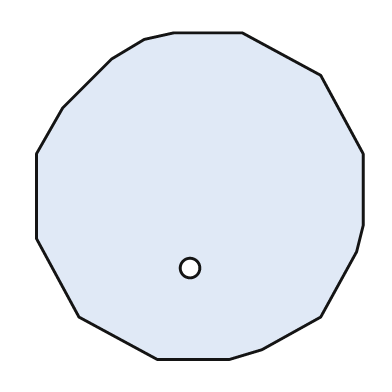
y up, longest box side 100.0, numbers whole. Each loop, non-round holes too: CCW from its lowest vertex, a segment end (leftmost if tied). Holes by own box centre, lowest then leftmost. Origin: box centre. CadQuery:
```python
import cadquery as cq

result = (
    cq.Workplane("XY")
    .moveTo(-13.0, -50.0)
    .lineTo(9.0, -50.0)
    .lineTo(19.0, -47.0)
    .lineTo(37.0, -37.0)
    .lineTo(48.0, -17.0)
    .lineTo(50.0, -9.0)
    .lineTo(50.0, 13.0)
    .lineTo(37.0, 37.0)
    .lineTo(13.0, 50.0)
    .lineTo(-8.0, 50.0)
    .lineTo(-17.0, 48.0)
    .lineTo(-27.0, 42.0)
    .lineTo(-42.0, 27.0)
    .lineTo(-50.0, 13.0)
    .lineTo(-50.0, -13.0)
    .lineTo(-37.0, -37.0)
    .close()
    .moveTo(-3.0, -22.0)
    .circle(3.0)
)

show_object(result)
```